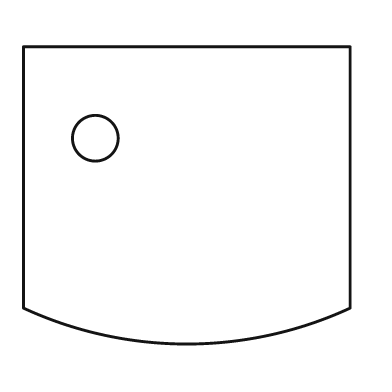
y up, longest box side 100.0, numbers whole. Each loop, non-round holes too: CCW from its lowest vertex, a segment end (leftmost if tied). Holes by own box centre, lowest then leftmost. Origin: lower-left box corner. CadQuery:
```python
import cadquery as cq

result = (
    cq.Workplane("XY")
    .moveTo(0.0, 11.0)
    .threePointArc((50.0, 0.0), (100.0, 11.0))
    .lineTo(100.0, 91.0)
    .lineTo(0.0, 91.0)
    .close()
    .moveTo(22.0, 63.0)
    .circle(7.0)
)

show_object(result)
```